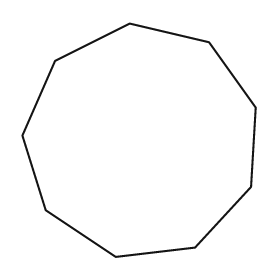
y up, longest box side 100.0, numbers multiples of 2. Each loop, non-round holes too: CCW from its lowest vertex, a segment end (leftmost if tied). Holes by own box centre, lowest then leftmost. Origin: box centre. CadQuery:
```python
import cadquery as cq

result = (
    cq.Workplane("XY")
    .moveTo(-10.0, -50.0)
    .lineTo(24.0, -46.0)
    .lineTo(48.0, -20.0)
    .lineTo(50.0, 14.0)
    .lineTo(30.0, 42.0)
    .lineTo(-4.0, 50.0)
    .lineTo(-36.0, 34.0)
    .lineTo(-50.0, 2.0)
    .lineTo(-40.0, -30.0)
    .close()
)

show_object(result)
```